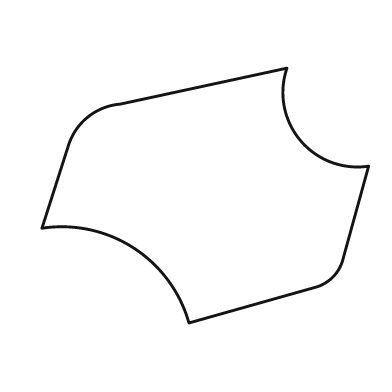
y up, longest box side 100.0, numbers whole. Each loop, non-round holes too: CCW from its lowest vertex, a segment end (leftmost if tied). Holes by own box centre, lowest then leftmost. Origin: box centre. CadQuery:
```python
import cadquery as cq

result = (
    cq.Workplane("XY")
    .moveTo(-5.0, -39.0)
    .lineTo(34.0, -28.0)
    .threePointArc((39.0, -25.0), (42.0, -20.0))
    .lineTo(50.0, 9.0)
    .threePointArc((29.0, 17.0), (25.0, 39.0))
    .lineTo(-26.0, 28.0)
    .threePointArc((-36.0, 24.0), (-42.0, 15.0))
    .lineTo(-50.0, -10.0)
    .threePointArc((-22.0, -16.0), (-5.0, -39.0))
    .close()
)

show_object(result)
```